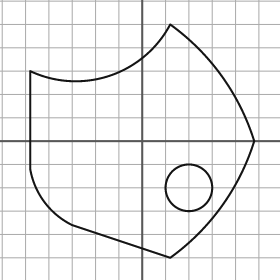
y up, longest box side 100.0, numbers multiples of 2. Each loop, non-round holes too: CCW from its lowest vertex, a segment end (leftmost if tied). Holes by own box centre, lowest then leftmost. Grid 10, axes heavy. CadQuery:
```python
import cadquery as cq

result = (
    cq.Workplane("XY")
    .moveTo(12.0, -50.0)
    .threePointArc((34.0, -28.0), (48.0, 0.0))
    .threePointArc((34.0, 28.0), (12.0, 50.0))
    .threePointArc((-14.0, 28.0), (-48.0, 30.0))
    .lineTo(-48.0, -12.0)
    .threePointArc((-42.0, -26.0), (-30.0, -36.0))
    .close()
    .moveTo(20.0, -20.0)
    .circle(10.0)
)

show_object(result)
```